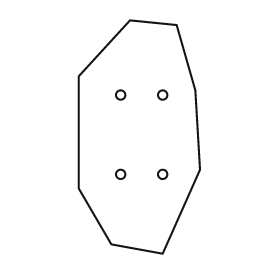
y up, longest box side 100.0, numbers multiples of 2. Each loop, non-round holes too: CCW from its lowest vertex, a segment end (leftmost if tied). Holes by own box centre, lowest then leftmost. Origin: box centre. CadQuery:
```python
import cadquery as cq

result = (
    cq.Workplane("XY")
    .moveTo(10.0, -50.0)
    .lineTo(26.0, -14.0)
    .lineTo(24.0, 20.0)
    .lineTo(16.0, 48.0)
    .lineTo(-4.0, 50.0)
    .lineTo(-26.0, 26.0)
    .lineTo(-26.0, -22.0)
    .lineTo(-12.0, -46.0)
    .close()
    .moveTo(-8.0, -16.0)
    .circle(2.0)
    .moveTo(10.0, -16.0)
    .circle(2.0)
    .moveTo(-8.0, 18.0)
    .circle(2.0)
    .moveTo(10.0, 18.0)
    .circle(2.0)
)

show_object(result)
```